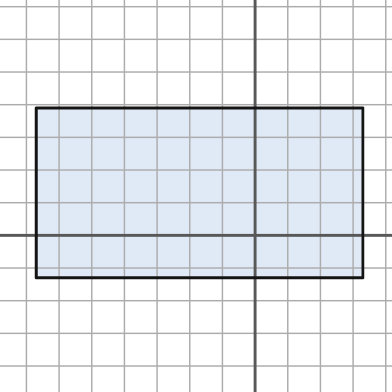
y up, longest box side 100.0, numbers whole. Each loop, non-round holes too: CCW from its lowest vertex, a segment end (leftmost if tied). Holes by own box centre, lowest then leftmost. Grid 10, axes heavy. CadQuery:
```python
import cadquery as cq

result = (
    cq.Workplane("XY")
    .moveTo(-67.0, -13.0)
    .lineTo(33.0, -13.0)
    .lineTo(33.0, 39.0)
    .lineTo(-67.0, 39.0)
    .close()
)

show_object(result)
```